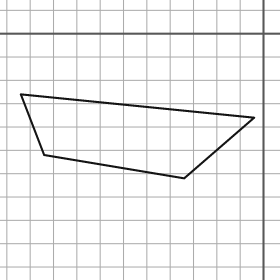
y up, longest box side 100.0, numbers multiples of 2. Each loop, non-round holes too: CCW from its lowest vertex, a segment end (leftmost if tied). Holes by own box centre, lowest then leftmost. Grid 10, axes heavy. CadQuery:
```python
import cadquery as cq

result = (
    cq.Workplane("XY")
    .moveTo(-34.0, -62.0)
    .lineTo(-4.0, -36.0)
    .lineTo(-104.0, -26.0)
    .lineTo(-94.0, -52.0)
    .close()
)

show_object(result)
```